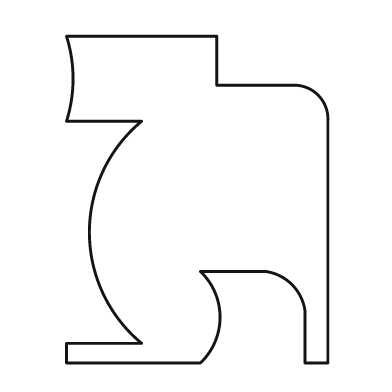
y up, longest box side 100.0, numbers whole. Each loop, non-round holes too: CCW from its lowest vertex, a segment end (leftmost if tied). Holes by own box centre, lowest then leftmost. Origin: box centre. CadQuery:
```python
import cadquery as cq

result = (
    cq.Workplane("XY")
    .moveTo(-40.0, -50.0)
    .lineTo(1.0, -50.0)
    .threePointArc((7.0, -36.0), (1.0, -22.0))
    .lineTo(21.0, -22.0)
    .threePointArc((29.0, -26.0), (33.0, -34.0))
    .lineTo(33.0, -50.0)
    .lineTo(40.0, -50.0)
    .lineTo(40.0, 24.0)
    .threePointArc((37.0, 32.0), (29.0, 35.0))
    .lineTo(6.0, 35.0)
    .lineTo(6.0, 50.0)
    .lineTo(-40.0, 50.0)
    .threePointArc((-38.0, 37.0), (-40.0, 24.0))
    .lineTo(-17.0, 24.0)
    .threePointArc((-33.0, -10.0), (-17.0, -44.0))
    .lineTo(-40.0, -44.0)
    .close()
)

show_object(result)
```